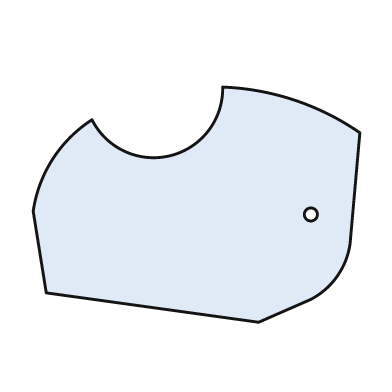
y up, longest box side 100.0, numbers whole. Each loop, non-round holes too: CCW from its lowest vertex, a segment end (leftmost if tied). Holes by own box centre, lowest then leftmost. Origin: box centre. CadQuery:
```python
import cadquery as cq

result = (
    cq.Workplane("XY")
    .moveTo(19.0, -36.0)
    .lineTo(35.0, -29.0)
    .threePointArc((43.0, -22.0), (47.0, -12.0))
    .lineTo(50.0, 22.0)
    .threePointArc((30.0, 32.0), (8.0, 36.0))
    .threePointArc((-8.0, 15.0), (-32.0, 26.0))
    .threePointArc((-44.0, 14.0), (-50.0, -2.0))
    .lineTo(-46.0, -27.0)
    .close()
    .moveTo(35.0, -3.0)
    .circle(2.0)
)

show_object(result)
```